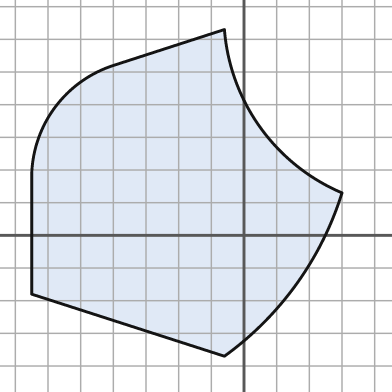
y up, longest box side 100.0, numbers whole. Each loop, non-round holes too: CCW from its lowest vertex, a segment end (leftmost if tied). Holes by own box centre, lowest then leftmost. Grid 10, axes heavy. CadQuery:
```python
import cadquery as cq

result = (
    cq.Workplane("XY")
    .moveTo(-6.0, -37.0)
    .threePointArc((16.0, -15.0), (30.0, 13.0))
    .threePointArc((5.0, 33.0), (-6.0, 63.0))
    .lineTo(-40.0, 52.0)
    .threePointArc((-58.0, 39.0), (-65.0, 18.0))
    .lineTo(-65.0, -18.0)
    .close()
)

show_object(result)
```